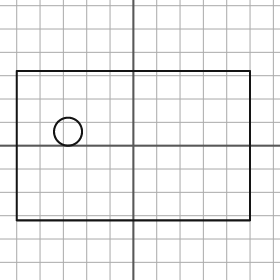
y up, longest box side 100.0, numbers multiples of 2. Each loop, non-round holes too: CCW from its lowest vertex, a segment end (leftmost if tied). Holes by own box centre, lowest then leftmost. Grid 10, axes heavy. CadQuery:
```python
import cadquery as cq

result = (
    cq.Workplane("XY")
    .moveTo(-50.0, -32.0)
    .lineTo(50.0, -32.0)
    .lineTo(50.0, 32.0)
    .lineTo(-50.0, 32.0)
    .close()
    .moveTo(-28.0, 6.0)
    .circle(6.0)
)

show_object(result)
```